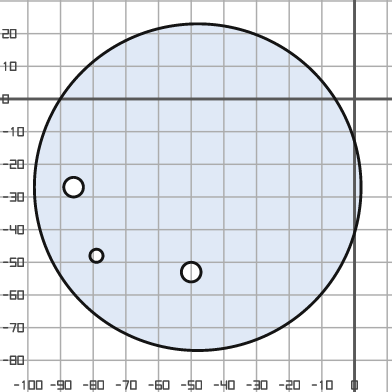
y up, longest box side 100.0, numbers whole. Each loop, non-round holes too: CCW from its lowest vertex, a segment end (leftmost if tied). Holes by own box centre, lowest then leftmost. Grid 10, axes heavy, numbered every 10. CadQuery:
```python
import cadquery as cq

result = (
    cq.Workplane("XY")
    .moveTo(-48.0, -27.0)
    .circle(50.0)
    .moveTo(-50.0, -53.0)
    .circle(3.0)
    .moveTo(-79.0, -48.0)
    .circle(2.0)
    .moveTo(-86.0, -27.0)
    .circle(3.0)
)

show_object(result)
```